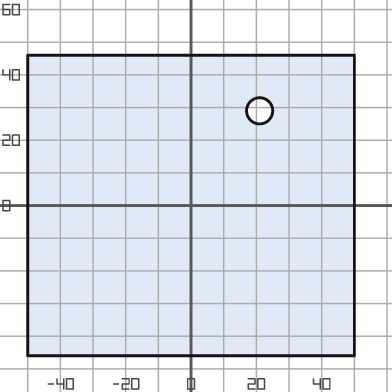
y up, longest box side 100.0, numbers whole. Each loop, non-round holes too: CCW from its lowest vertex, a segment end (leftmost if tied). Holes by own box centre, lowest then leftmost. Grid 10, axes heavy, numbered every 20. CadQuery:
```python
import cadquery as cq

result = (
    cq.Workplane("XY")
    .moveTo(-50.0, -46.0)
    .lineTo(50.0, -46.0)
    .lineTo(50.0, 46.0)
    .lineTo(-50.0, 46.0)
    .close()
    .moveTo(21.0, 29.0)
    .circle(4.0)
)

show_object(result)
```